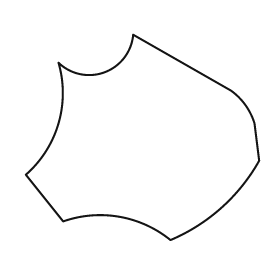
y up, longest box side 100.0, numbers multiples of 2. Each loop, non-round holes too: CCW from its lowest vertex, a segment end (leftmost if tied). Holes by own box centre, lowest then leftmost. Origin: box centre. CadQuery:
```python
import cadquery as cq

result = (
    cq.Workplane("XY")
    .moveTo(12.0, -44.0)
    .threePointArc((34.0, -30.0), (50.0, -10.0))
    .lineTo(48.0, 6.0)
    .threePointArc((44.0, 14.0), (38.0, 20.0))
    .lineTo(-4.0, 44.0)
    .threePointArc((-16.0, 28.0), (-36.0, 32.0))
    .threePointArc((-36.0, 6.0), (-50.0, -16.0))
    .lineTo(-34.0, -36.0)
    .threePointArc((-10.0, -34.0), (12.0, -44.0))
    .close()
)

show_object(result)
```